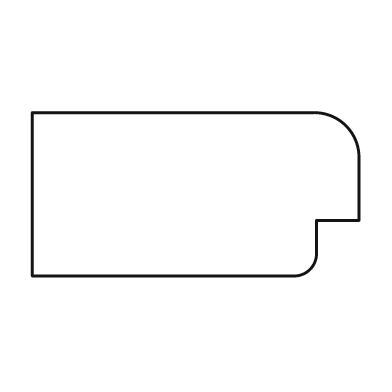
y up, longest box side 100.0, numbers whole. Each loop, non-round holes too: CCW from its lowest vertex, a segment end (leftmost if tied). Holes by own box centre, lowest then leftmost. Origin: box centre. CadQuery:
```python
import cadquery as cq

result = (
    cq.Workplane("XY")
    .moveTo(-50.0, -25.0)
    .lineTo(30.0, -25.0)
    .threePointArc((35.0, -23.0), (37.0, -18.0))
    .lineTo(37.0, -8.0)
    .lineTo(50.0, -8.0)
    .lineTo(50.0, 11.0)
    .threePointArc((46.0, 21.0), (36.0, 25.0))
    .lineTo(-50.0, 25.0)
    .close()
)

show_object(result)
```